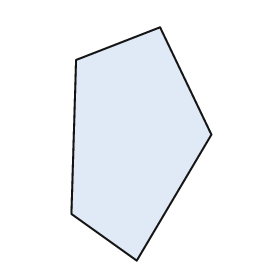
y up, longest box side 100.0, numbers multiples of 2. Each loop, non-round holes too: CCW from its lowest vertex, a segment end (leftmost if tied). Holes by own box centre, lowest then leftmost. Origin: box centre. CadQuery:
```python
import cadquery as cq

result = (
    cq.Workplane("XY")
    .moveTo(-2.0, -50.0)
    .lineTo(30.0, 4.0)
    .lineTo(8.0, 50.0)
    .lineTo(-28.0, 36.0)
    .lineTo(-30.0, -30.0)
    .close()
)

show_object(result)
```